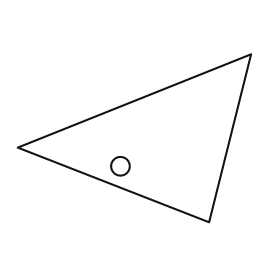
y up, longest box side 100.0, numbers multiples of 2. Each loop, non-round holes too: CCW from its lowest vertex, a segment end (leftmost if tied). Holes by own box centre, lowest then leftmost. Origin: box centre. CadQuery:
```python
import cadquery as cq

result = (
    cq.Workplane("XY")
    .moveTo(32.0, -36.0)
    .lineTo(50.0, 36.0)
    .lineTo(-50.0, -4.0)
    .close()
    .moveTo(-6.0, -12.0)
    .circle(4.0)
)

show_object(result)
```